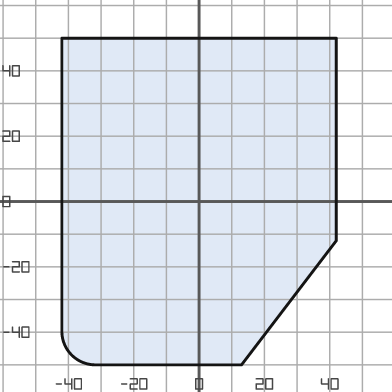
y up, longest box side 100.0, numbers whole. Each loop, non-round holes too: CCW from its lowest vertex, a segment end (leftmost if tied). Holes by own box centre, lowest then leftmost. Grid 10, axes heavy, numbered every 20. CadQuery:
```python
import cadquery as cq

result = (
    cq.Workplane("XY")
    .moveTo(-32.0, -50.0)
    .lineTo(13.0, -50.0)
    .lineTo(42.0, -12.0)
    .lineTo(42.0, 50.0)
    .lineTo(-42.0, 50.0)
    .lineTo(-42.0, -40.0)
    .threePointArc((-39.0, -47.0), (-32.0, -50.0))
    .close()
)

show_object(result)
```